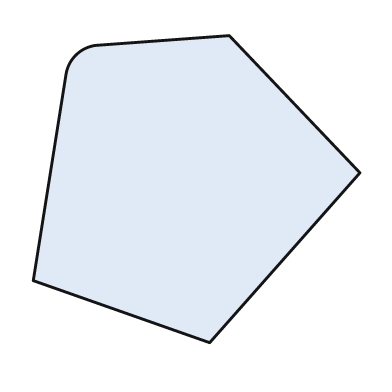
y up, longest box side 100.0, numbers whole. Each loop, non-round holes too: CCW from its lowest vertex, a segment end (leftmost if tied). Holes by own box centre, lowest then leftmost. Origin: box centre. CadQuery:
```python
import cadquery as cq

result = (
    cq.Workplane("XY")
    .moveTo(4.0, -47.0)
    .lineTo(50.0, 5.0)
    .lineTo(10.0, 47.0)
    .lineTo(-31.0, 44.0)
    .threePointArc((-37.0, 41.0), (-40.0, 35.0))
    .lineTo(-50.0, -28.0)
    .close()
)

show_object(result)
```